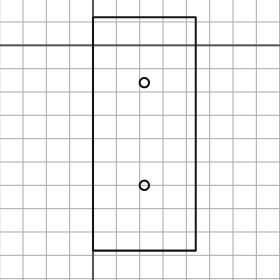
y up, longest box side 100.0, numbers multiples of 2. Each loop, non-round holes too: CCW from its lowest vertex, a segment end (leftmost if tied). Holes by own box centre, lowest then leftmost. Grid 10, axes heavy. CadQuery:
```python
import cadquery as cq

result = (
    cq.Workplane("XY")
    .moveTo(0.0, -88.0)
    .lineTo(44.0, -88.0)
    .lineTo(44.0, 12.0)
    .lineTo(0.0, 12.0)
    .close()
    .moveTo(22.0, -60.0)
    .circle(2.0)
    .moveTo(22.0, -16.0)
    .circle(2.0)
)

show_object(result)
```